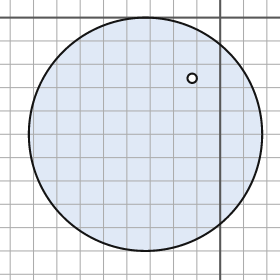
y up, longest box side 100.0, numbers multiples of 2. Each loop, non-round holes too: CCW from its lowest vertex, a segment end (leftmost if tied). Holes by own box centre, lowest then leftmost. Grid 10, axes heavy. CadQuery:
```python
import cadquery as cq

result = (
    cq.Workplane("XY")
    .moveTo(-32.0, -50.0)
    .circle(50.0)
    .moveTo(-12.0, -26.0)
    .circle(2.0)
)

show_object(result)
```